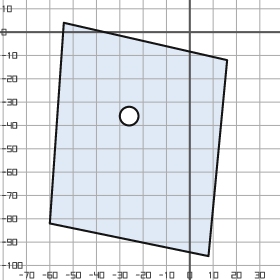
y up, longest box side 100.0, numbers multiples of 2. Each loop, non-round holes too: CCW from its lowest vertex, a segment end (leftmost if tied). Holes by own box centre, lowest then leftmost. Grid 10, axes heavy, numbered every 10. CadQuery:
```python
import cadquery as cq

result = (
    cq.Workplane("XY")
    .moveTo(8.0, -96.0)
    .lineTo(16.0, -12.0)
    .lineTo(-54.0, 4.0)
    .lineTo(-60.0, -82.0)
    .close()
    .moveTo(-26.0, -36.0)
    .circle(4.0)
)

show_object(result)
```